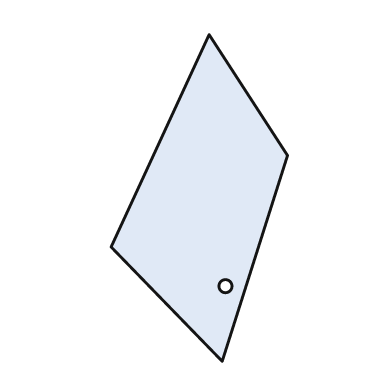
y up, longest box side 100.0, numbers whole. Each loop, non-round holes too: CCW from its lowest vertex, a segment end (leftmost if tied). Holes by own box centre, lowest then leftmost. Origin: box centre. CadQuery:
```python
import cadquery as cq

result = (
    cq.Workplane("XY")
    .moveTo(7.0, -50.0)
    .lineTo(27.0, 13.0)
    .lineTo(3.0, 50.0)
    .lineTo(-27.0, -15.0)
    .close()
    .moveTo(8.0, -27.0)
    .circle(2.0)
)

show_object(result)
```